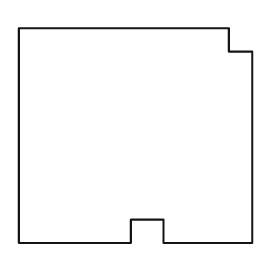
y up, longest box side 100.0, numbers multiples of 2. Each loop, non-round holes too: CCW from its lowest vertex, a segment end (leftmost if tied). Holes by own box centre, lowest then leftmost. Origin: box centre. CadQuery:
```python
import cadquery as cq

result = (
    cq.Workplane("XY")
    .moveTo(-50.0, -46.0)
    .lineTo(-2.0, -46.0)
    .lineTo(-2.0, -36.0)
    .lineTo(12.0, -36.0)
    .lineTo(12.0, -46.0)
    .lineTo(50.0, -46.0)
    .lineTo(50.0, 36.0)
    .lineTo(40.0, 36.0)
    .lineTo(40.0, 46.0)
    .lineTo(-50.0, 46.0)
    .close()
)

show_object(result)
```